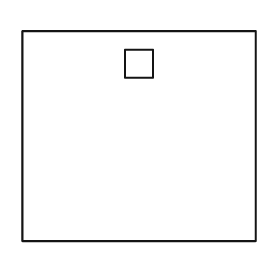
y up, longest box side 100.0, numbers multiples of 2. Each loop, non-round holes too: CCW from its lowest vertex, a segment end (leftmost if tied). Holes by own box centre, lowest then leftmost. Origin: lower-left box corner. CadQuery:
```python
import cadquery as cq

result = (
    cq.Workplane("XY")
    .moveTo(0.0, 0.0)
    .lineTo(100.0, 0.0)
    .lineTo(100.0, 90.0)
    .lineTo(0.0, 90.0)
    .close()
    .moveTo(44.0, 70.0)
    .lineTo(56.0, 70.0)
    .lineTo(56.0, 82.0)
    .lineTo(44.0, 82.0)
    .close()
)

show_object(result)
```